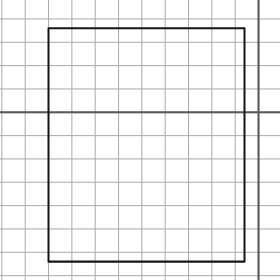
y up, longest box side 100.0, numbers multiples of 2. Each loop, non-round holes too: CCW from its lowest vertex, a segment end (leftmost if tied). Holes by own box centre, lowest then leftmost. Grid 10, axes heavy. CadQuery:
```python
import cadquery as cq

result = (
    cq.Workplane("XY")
    .moveTo(-90.0, -64.0)
    .lineTo(-6.0, -64.0)
    .lineTo(-6.0, 36.0)
    .lineTo(-90.0, 36.0)
    .close()
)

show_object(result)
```